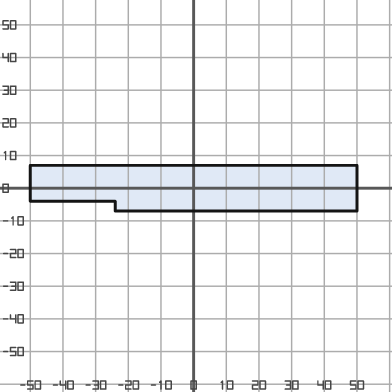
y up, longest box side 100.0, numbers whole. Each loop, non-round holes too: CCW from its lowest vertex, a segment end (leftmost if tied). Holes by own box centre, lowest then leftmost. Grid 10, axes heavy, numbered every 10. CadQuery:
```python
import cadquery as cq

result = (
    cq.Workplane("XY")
    .moveTo(-24.0, -7.0)
    .lineTo(50.0, -7.0)
    .lineTo(50.0, 7.0)
    .lineTo(-50.0, 7.0)
    .lineTo(-50.0, -4.0)
    .lineTo(-24.0, -4.0)
    .close()
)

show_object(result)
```